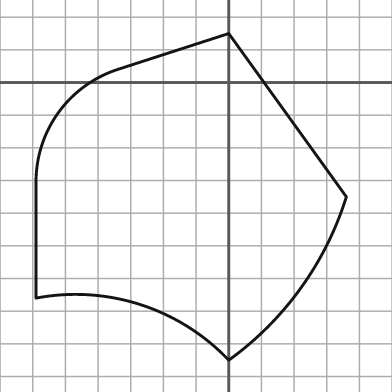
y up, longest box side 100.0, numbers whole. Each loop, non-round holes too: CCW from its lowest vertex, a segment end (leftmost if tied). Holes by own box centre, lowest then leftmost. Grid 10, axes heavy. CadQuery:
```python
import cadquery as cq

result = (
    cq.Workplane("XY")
    .moveTo(0.0, -85.0)
    .threePointArc((22.0, -63.0), (36.0, -35.0))
    .lineTo(0.0, 15.0)
    .lineTo(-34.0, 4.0)
    .threePointArc((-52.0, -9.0), (-59.0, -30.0))
    .lineTo(-59.0, -66.0)
    .threePointArc((-27.0, -68.0), (0.0, -85.0))
    .close()
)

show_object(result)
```